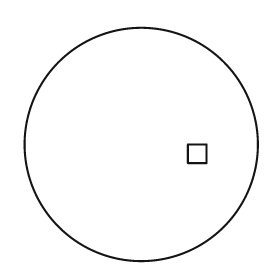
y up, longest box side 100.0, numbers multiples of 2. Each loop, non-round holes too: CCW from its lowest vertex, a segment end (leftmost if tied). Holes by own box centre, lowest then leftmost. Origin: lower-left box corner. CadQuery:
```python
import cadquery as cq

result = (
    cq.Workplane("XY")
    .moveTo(50.0, 50.0)
    .circle(50.0)
    .moveTo(70.0, 42.0)
    .lineTo(78.0, 42.0)
    .lineTo(78.0, 50.0)
    .lineTo(70.0, 50.0)
    .close()
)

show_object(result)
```